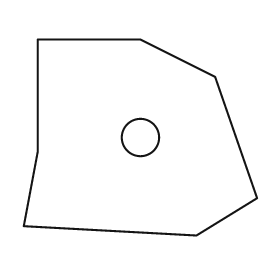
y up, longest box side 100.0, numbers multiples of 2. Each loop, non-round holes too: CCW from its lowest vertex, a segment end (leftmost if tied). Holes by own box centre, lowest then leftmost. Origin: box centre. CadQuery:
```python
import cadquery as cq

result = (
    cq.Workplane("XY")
    .moveTo(24.0, -42.0)
    .lineTo(50.0, -26.0)
    .lineTo(32.0, 26.0)
    .lineTo(0.0, 42.0)
    .lineTo(-44.0, 42.0)
    .lineTo(-44.0, -6.0)
    .lineTo(-50.0, -38.0)
    .close()
    .moveTo(0.0, 0.0)
    .circle(8.0)
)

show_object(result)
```